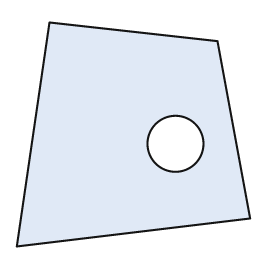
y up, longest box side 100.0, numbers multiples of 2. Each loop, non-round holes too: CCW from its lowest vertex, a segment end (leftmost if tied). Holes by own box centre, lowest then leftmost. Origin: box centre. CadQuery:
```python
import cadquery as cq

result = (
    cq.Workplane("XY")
    .moveTo(-50.0, -48.0)
    .lineTo(50.0, -36.0)
    .lineTo(36.0, 40.0)
    .lineTo(-36.0, 48.0)
    .close()
    .moveTo(18.0, -4.0)
    .circle(12.0)
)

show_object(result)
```